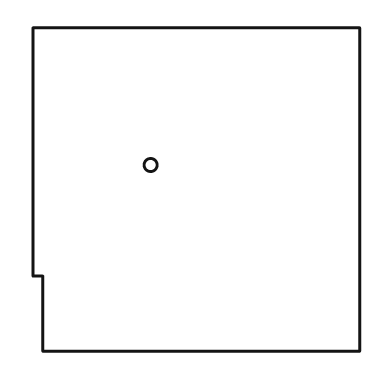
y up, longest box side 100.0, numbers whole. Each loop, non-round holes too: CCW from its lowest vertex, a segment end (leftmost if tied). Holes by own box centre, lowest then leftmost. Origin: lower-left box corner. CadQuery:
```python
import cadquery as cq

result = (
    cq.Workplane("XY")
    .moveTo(3.0, 0.0)
    .lineTo(100.0, 0.0)
    .lineTo(100.0, 99.0)
    .lineTo(0.0, 99.0)
    .lineTo(0.0, 23.0)
    .lineTo(3.0, 23.0)
    .close()
    .moveTo(36.0, 57.0)
    .circle(2.0)
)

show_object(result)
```